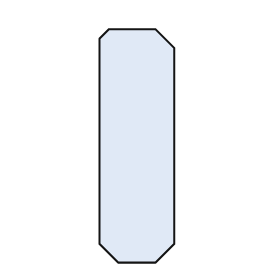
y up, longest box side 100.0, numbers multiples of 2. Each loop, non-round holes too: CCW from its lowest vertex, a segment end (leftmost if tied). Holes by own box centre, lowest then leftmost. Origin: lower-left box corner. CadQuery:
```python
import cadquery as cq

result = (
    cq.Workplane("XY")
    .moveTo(8.0, 0.0)
    .lineTo(24.0, 0.0)
    .lineTo(32.0, 8.0)
    .lineTo(32.0, 92.0)
    .lineTo(24.0, 100.0)
    .lineTo(4.0, 100.0)
    .lineTo(0.0, 96.0)
    .lineTo(0.0, 8.0)
    .close()
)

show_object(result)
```